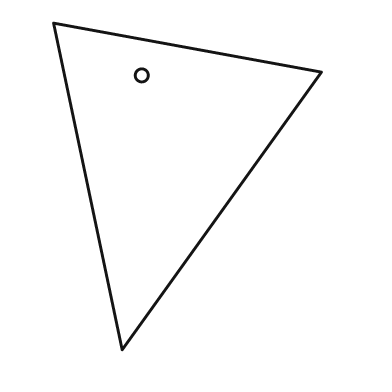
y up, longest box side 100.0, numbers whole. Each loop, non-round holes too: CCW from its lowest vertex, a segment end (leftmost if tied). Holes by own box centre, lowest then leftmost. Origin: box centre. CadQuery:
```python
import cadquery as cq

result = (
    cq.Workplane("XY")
    .moveTo(-20.0, -50.0)
    .lineTo(41.0, 35.0)
    .lineTo(-41.0, 50.0)
    .close()
    .moveTo(-14.0, 34.0)
    .circle(2.0)
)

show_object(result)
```